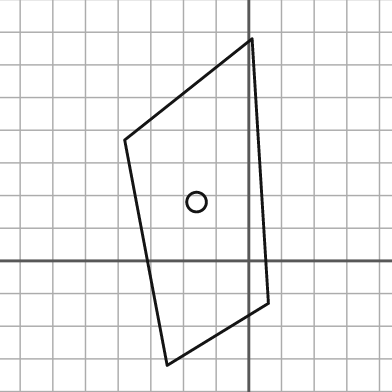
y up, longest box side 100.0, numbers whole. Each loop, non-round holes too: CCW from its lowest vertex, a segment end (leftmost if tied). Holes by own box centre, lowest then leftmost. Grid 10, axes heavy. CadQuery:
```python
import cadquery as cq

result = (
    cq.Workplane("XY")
    .moveTo(-25.0, -32.0)
    .lineTo(6.0, -13.0)
    .lineTo(1.0, 68.0)
    .lineTo(-38.0, 37.0)
    .close()
    .moveTo(-16.0, 18.0)
    .circle(3.0)
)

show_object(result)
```